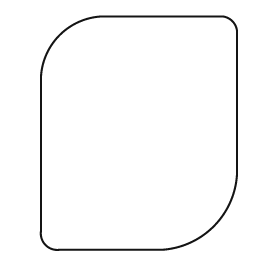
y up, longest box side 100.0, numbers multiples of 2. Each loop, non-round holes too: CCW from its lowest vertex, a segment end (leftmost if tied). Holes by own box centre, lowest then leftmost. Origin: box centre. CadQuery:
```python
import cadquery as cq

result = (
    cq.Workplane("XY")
    .moveTo(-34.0, -50.0)
    .lineTo(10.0, -50.0)
    .threePointArc((32.0, -40.0), (42.0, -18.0))
    .lineTo(42.0, 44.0)
    .threePointArc((40.0, 48.0), (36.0, 50.0))
    .lineTo(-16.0, 50.0)
    .threePointArc((-34.0, 42.0), (-42.0, 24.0))
    .lineTo(-42.0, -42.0)
    .threePointArc((-40.0, -48.0), (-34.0, -50.0))
    .close()
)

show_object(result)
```